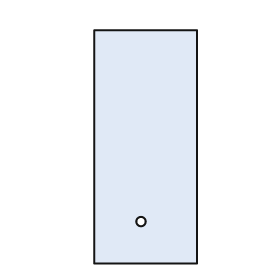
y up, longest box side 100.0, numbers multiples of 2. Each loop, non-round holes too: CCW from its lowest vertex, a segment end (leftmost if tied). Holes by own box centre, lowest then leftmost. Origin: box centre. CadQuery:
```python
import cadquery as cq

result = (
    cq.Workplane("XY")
    .moveTo(-22.0, -50.0)
    .lineTo(22.0, -50.0)
    .lineTo(22.0, 50.0)
    .lineTo(-22.0, 50.0)
    .close()
    .moveTo(-2.0, -32.0)
    .circle(2.0)
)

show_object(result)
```